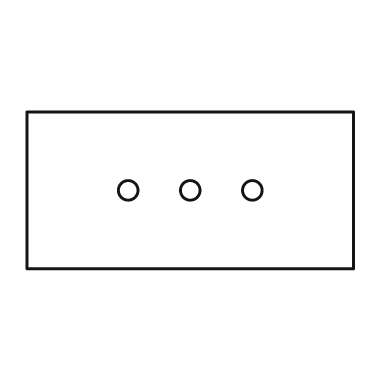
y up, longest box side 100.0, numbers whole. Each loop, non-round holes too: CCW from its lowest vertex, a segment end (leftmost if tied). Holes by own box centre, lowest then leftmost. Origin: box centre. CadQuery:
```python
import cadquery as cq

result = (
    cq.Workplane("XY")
    .moveTo(-50.0, -24.0)
    .lineTo(50.0, -24.0)
    .lineTo(50.0, 24.0)
    .lineTo(-50.0, 24.0)
    .close()
    .moveTo(-19.0, 0.0)
    .circle(3.0)
    .moveTo(0.0, 0.0)
    .circle(3.0)
    .moveTo(19.0, 0.0)
    .circle(3.0)
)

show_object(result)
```